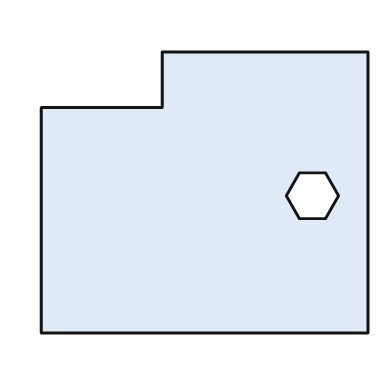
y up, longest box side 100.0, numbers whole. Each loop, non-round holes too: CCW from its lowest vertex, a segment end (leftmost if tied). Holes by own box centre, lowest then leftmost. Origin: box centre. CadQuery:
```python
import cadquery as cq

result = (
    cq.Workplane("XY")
    .moveTo(-50.0, -43.0)
    .lineTo(50.0, -43.0)
    .lineTo(50.0, 43.0)
    .lineTo(-13.0, 43.0)
    .lineTo(-13.0, 26.0)
    .lineTo(-50.0, 26.0)
    .close()
    .moveTo(29.0, -8.0)
    .lineTo(37.0, -8.0)
    .lineTo(41.0, -1.0)
    .lineTo(37.0, 6.0)
    .lineTo(29.0, 6.0)
    .lineTo(25.0, -1.0)
    .close()
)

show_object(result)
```